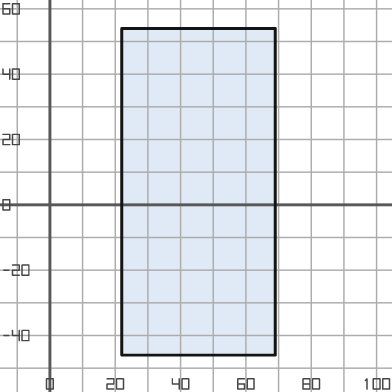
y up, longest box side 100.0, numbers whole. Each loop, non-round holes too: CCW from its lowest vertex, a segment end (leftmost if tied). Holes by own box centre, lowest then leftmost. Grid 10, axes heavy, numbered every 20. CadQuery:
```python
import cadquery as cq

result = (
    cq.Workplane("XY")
    .moveTo(22.0, -46.0)
    .lineTo(69.0, -46.0)
    .lineTo(69.0, 54.0)
    .lineTo(22.0, 54.0)
    .close()
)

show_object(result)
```